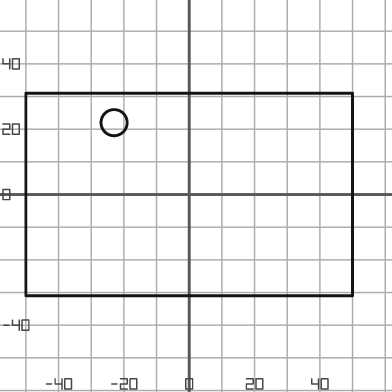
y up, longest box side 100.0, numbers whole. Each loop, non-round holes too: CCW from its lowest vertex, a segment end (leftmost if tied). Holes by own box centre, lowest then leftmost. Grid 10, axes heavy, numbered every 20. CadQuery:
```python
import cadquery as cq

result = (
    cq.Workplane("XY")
    .moveTo(-50.0, -31.0)
    .lineTo(50.0, -31.0)
    .lineTo(50.0, 31.0)
    .lineTo(-50.0, 31.0)
    .close()
    .moveTo(-23.0, 22.0)
    .circle(4.0)
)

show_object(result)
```